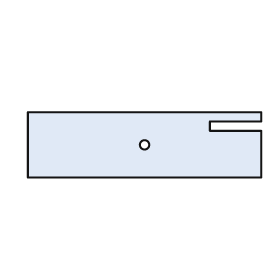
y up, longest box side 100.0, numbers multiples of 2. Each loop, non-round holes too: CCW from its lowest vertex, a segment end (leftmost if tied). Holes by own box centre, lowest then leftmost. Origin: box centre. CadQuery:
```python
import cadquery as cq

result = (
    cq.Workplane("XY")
    .moveTo(-50.0, -14.0)
    .lineTo(50.0, -14.0)
    .lineTo(50.0, 6.0)
    .lineTo(28.0, 6.0)
    .lineTo(28.0, 10.0)
    .lineTo(50.0, 10.0)
    .lineTo(50.0, 14.0)
    .lineTo(-50.0, 14.0)
    .close()
    .moveTo(0.0, 0.0)
    .circle(2.0)
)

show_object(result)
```